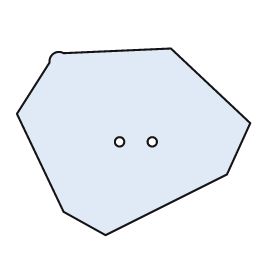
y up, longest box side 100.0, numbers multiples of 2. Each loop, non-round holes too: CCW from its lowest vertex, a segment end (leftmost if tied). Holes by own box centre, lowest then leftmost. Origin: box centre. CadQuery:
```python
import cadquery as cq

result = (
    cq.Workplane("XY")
    .moveTo(-12.0, -40.0)
    .lineTo(40.0, -14.0)
    .lineTo(50.0, 8.0)
    .lineTo(16.0, 40.0)
    .lineTo(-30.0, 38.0)
    .threePointArc((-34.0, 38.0), (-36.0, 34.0))
    .lineTo(-50.0, 12.0)
    .lineTo(-30.0, -30.0)
    .close()
    .moveTo(-6.0, 0.0)
    .circle(2.0)
    .moveTo(8.0, 0.0)
    .circle(2.0)
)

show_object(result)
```